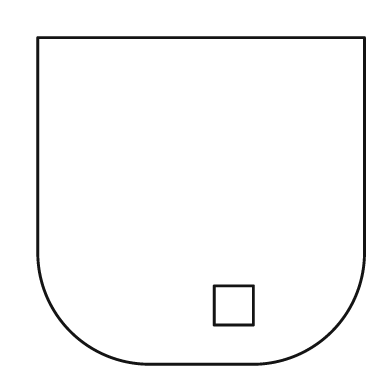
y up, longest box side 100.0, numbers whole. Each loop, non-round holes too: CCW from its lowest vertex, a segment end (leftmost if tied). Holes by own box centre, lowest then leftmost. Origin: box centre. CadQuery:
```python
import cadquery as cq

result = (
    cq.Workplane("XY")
    .moveTo(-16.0, -50.0)
    .lineTo(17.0, -50.0)
    .threePointArc((40.0, -40.0), (50.0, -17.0))
    .lineTo(50.0, 50.0)
    .lineTo(-50.0, 50.0)
    .lineTo(-50.0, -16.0)
    .threePointArc((-40.0, -40.0), (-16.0, -50.0))
    .close()
    .moveTo(4.0, -38.0)
    .lineTo(16.0, -38.0)
    .lineTo(16.0, -26.0)
    .lineTo(4.0, -26.0)
    .close()
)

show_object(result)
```